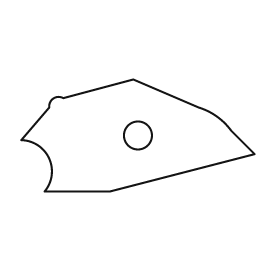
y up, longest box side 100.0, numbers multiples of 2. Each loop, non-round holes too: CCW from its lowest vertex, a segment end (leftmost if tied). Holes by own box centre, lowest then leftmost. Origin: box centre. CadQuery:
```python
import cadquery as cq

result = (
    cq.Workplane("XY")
    .moveTo(-40.0, -24.0)
    .lineTo(-12.0, -24.0)
    .lineTo(50.0, -8.0)
    .lineTo(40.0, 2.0)
    .threePointArc((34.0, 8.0), (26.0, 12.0))
    .lineTo(-2.0, 24.0)
    .lineTo(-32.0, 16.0)
    .threePointArc((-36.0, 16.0), (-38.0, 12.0))
    .lineTo(-50.0, -2.0)
    .threePointArc((-38.0, -10.0), (-40.0, -24.0))
    .close()
    .moveTo(0.0, 0.0)
    .circle(6.0)
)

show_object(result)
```